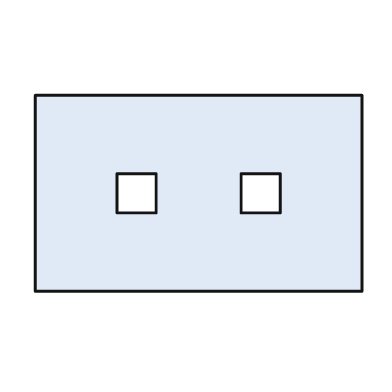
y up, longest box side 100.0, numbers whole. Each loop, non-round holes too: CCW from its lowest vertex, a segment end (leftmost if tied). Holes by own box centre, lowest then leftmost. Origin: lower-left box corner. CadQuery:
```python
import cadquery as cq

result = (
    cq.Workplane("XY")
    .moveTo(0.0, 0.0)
    .lineTo(100.0, 0.0)
    .lineTo(100.0, 60.0)
    .lineTo(0.0, 60.0)
    .close()
    .moveTo(25.0, 24.0)
    .lineTo(37.0, 24.0)
    .lineTo(37.0, 36.0)
    .lineTo(25.0, 36.0)
    .close()
    .moveTo(63.0, 24.0)
    .lineTo(75.0, 24.0)
    .lineTo(75.0, 36.0)
    .lineTo(63.0, 36.0)
    .close()
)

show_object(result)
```